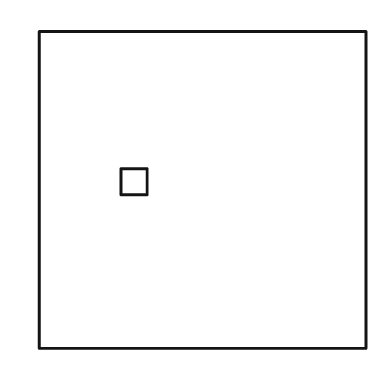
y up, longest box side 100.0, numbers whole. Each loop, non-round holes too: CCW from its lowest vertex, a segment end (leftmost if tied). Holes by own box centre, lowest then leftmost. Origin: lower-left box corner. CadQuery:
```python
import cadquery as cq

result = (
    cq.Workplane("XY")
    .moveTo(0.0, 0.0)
    .lineTo(100.0, 0.0)
    .lineTo(100.0, 97.0)
    .lineTo(0.0, 97.0)
    .close()
    .moveTo(25.0, 47.0)
    .lineTo(33.0, 47.0)
    .lineTo(33.0, 55.0)
    .lineTo(25.0, 55.0)
    .close()
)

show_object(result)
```